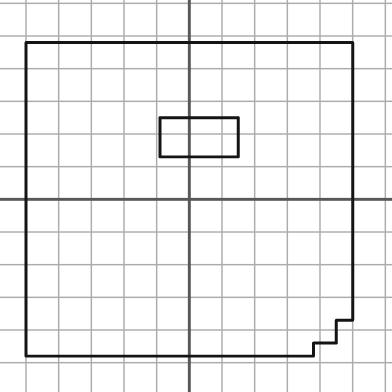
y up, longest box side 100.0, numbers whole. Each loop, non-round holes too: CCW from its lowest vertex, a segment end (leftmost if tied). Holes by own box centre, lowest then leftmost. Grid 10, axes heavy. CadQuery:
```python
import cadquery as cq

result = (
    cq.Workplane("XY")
    .moveTo(-50.0, -48.0)
    .lineTo(38.0, -48.0)
    .lineTo(38.0, -44.0)
    .lineTo(45.0, -44.0)
    .lineTo(45.0, -37.0)
    .lineTo(50.0, -37.0)
    .lineTo(50.0, 48.0)
    .lineTo(-50.0, 48.0)
    .close()
    .moveTo(-9.0, 13.0)
    .lineTo(15.0, 13.0)
    .lineTo(15.0, 25.0)
    .lineTo(-9.0, 25.0)
    .close()
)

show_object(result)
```